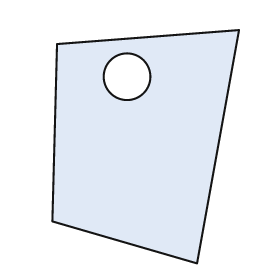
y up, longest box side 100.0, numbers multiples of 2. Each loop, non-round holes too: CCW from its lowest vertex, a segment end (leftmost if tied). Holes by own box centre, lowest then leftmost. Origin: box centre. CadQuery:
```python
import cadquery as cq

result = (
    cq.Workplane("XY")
    .moveTo(22.0, -50.0)
    .lineTo(40.0, 50.0)
    .lineTo(-38.0, 44.0)
    .lineTo(-40.0, -32.0)
    .close()
    .moveTo(-8.0, 30.0)
    .circle(10.0)
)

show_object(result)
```